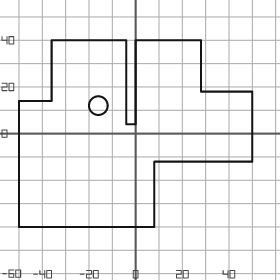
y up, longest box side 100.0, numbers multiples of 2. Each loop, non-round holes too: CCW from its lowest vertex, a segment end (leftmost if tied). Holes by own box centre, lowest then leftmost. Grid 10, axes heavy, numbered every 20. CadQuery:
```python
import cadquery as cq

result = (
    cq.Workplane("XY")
    .moveTo(-50.0, -40.0)
    .lineTo(8.0, -40.0)
    .lineTo(8.0, -12.0)
    .lineTo(50.0, -12.0)
    .lineTo(50.0, 18.0)
    .lineTo(28.0, 18.0)
    .lineTo(28.0, 40.0)
    .lineTo(0.0, 40.0)
    .lineTo(0.0, 4.0)
    .lineTo(-4.0, 4.0)
    .lineTo(-4.0, 40.0)
    .lineTo(-36.0, 40.0)
    .lineTo(-36.0, 14.0)
    .lineTo(-50.0, 14.0)
    .close()
    .moveTo(-16.0, 12.0)
    .circle(4.0)
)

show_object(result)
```